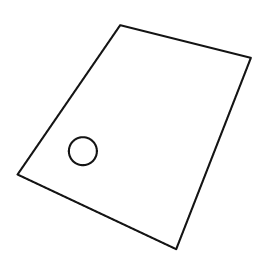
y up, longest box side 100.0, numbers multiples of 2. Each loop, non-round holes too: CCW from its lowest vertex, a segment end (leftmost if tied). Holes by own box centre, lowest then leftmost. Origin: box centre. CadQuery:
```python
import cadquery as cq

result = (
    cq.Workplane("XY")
    .moveTo(18.0, -48.0)
    .lineTo(50.0, 34.0)
    .lineTo(-6.0, 48.0)
    .lineTo(-50.0, -16.0)
    .close()
    .moveTo(-22.0, -6.0)
    .circle(6.0)
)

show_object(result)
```